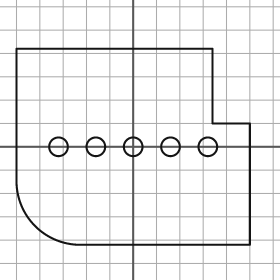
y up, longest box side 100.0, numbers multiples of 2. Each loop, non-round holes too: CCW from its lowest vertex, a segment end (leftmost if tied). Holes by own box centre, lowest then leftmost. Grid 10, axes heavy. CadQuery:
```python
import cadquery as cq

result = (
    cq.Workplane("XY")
    .moveTo(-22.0, -42.0)
    .lineTo(50.0, -42.0)
    .lineTo(50.0, 10.0)
    .lineTo(34.0, 10.0)
    .lineTo(34.0, 42.0)
    .lineTo(-50.0, 42.0)
    .lineTo(-50.0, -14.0)
    .threePointArc((-42.0, -34.0), (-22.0, -42.0))
    .close()
    .moveTo(-32.0, 0.0)
    .circle(4.0)
    .moveTo(-16.0, 0.0)
    .circle(4.0)
    .moveTo(0.0, 0.0)
    .circle(4.0)
    .moveTo(16.0, 0.0)
    .circle(4.0)
    .moveTo(32.0, 0.0)
    .circle(4.0)
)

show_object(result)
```